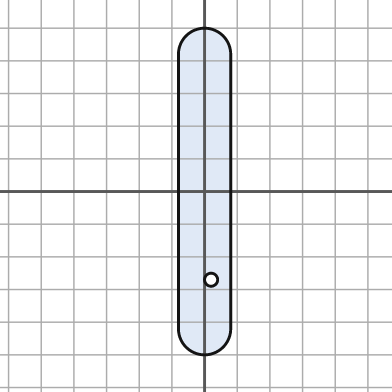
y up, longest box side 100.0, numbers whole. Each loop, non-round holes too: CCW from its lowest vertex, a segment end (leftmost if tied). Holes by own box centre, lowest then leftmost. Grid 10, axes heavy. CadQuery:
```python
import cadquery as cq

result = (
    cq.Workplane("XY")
    .moveTo(-8.0, -42.0)
    .threePointArc((0.0, -50.0), (8.0, -42.0))
    .lineTo(8.0, 42.0)
    .threePointArc((0.0, 50.0), (-8.0, 42.0))
    .close()
    .moveTo(2.0, -27.0)
    .circle(2.0)
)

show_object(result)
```